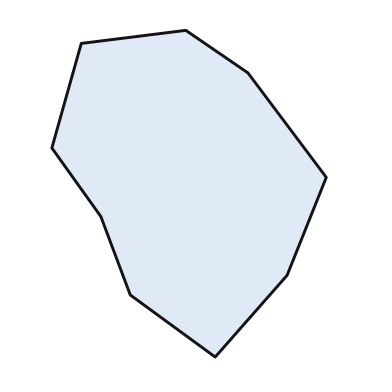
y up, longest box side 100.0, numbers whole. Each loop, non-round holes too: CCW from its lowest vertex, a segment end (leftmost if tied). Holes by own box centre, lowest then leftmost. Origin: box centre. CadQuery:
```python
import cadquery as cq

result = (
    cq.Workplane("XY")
    .moveTo(8.0, -50.0)
    .lineTo(30.0, -25.0)
    .lineTo(42.0, 5.0)
    .lineTo(18.0, 37.0)
    .lineTo(-1.0, 50.0)
    .lineTo(-33.0, 46.0)
    .lineTo(-42.0, 14.0)
    .lineTo(-27.0, -7.0)
    .lineTo(-18.0, -31.0)
    .close()
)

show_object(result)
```